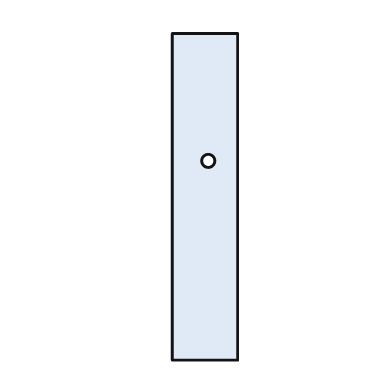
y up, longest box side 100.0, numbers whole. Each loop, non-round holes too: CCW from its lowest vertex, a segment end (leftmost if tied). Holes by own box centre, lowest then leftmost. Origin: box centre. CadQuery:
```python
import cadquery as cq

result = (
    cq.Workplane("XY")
    .moveTo(-10.0, -50.0)
    .lineTo(10.0, -50.0)
    .lineTo(10.0, 50.0)
    .lineTo(-10.0, 50.0)
    .close()
    .moveTo(1.0, 11.0)
    .circle(2.0)
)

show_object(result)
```